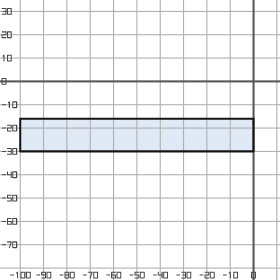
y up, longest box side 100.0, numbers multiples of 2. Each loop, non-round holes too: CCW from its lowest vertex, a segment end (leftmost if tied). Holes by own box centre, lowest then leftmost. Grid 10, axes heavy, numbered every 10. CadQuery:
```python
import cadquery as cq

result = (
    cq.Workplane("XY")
    .moveTo(-100.0, -30.0)
    .lineTo(0.0, -30.0)
    .lineTo(0.0, -16.0)
    .lineTo(-100.0, -16.0)
    .close()
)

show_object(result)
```